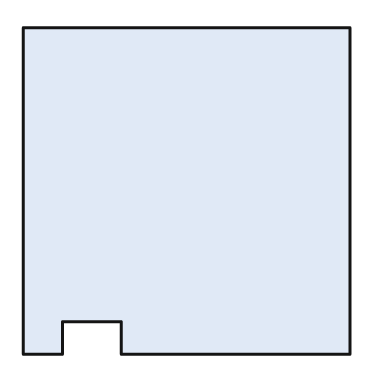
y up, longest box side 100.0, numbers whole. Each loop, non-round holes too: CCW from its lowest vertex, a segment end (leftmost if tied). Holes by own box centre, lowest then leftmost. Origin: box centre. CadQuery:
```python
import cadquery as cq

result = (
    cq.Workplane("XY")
    .moveTo(-50.0, -50.0)
    .lineTo(-38.0, -50.0)
    .lineTo(-38.0, -40.0)
    .lineTo(-20.0, -40.0)
    .lineTo(-20.0, -50.0)
    .lineTo(50.0, -50.0)
    .lineTo(50.0, 50.0)
    .lineTo(-50.0, 50.0)
    .close()
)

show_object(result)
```